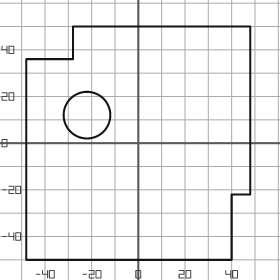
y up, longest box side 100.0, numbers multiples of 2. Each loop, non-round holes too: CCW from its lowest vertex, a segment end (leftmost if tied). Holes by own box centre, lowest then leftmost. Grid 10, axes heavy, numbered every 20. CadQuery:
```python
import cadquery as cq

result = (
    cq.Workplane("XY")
    .moveTo(-48.0, -50.0)
    .lineTo(40.0, -50.0)
    .lineTo(40.0, -22.0)
    .lineTo(48.0, -22.0)
    .lineTo(48.0, 50.0)
    .lineTo(-28.0, 50.0)
    .lineTo(-28.0, 36.0)
    .lineTo(-48.0, 36.0)
    .close()
    .moveTo(-22.0, 12.0)
    .circle(10.0)
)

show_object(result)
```